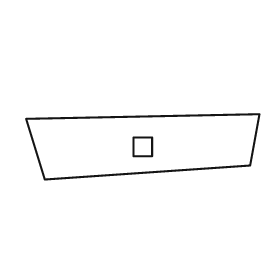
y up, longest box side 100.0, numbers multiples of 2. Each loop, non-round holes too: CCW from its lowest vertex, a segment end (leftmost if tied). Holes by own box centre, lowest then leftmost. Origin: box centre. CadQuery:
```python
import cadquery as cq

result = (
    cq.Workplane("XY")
    .moveTo(-42.0, -14.0)
    .lineTo(46.0, -8.0)
    .lineTo(50.0, 14.0)
    .lineTo(-50.0, 12.0)
    .close()
    .moveTo(-4.0, -4.0)
    .lineTo(4.0, -4.0)
    .lineTo(4.0, 4.0)
    .lineTo(-4.0, 4.0)
    .close()
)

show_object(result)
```